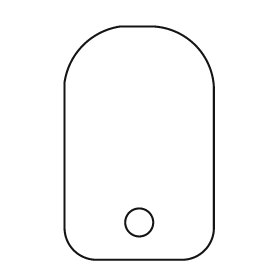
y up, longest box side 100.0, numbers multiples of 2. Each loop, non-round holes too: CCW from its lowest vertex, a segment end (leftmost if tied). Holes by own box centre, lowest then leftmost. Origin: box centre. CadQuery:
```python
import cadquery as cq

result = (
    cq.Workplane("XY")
    .moveTo(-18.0, -50.0)
    .lineTo(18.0, -50.0)
    .threePointArc((28.0, -46.0), (32.0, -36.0))
    .lineTo(32.0, 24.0)
    .threePointArc((24.0, 42.0), (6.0, 50.0))
    .lineTo(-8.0, 50.0)
    .threePointArc((-24.0, 42.0), (-32.0, 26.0))
    .lineTo(-32.0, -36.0)
    .threePointArc((-28.0, -46.0), (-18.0, -50.0))
    .close()
    .moveTo(0.0, -34.0)
    .circle(6.0)
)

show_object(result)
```